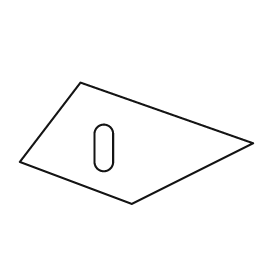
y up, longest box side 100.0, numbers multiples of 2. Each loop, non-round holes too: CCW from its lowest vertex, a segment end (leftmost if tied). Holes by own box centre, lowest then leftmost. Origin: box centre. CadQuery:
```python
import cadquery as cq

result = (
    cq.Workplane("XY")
    .moveTo(-2.0, -26.0)
    .lineTo(50.0, 0.0)
    .lineTo(-24.0, 26.0)
    .lineTo(-50.0, -8.0)
    .close()
    .moveTo(-18.0, -8.0)
    .threePointArc((-14.0, -12.0), (-10.0, -8.0))
    .lineTo(-10.0, 4.0)
    .threePointArc((-14.0, 8.0), (-18.0, 4.0))
    .close()
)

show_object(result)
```